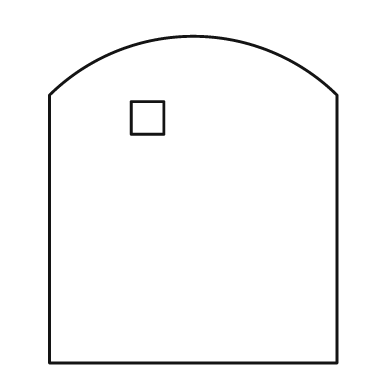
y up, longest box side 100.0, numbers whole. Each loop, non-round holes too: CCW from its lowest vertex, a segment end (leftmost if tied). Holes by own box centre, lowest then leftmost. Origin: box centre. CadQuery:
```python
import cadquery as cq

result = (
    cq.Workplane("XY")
    .moveTo(-44.0, -50.0)
    .lineTo(44.0, -50.0)
    .lineTo(44.0, 32.0)
    .threePointArc((0.0, 50.0), (-44.0, 32.0))
    .close()
    .moveTo(-19.0, 20.0)
    .lineTo(-9.0, 20.0)
    .lineTo(-9.0, 30.0)
    .lineTo(-19.0, 30.0)
    .close()
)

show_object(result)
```